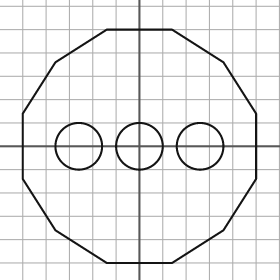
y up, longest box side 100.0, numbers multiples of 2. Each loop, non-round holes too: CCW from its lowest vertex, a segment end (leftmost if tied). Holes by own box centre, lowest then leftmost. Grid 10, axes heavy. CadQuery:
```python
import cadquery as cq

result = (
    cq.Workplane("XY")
    .moveTo(-14.0, -50.0)
    .lineTo(14.0, -50.0)
    .lineTo(36.0, -36.0)
    .lineTo(50.0, -14.0)
    .lineTo(50.0, 14.0)
    .lineTo(36.0, 36.0)
    .lineTo(14.0, 50.0)
    .lineTo(-14.0, 50.0)
    .lineTo(-36.0, 36.0)
    .lineTo(-50.0, 14.0)
    .lineTo(-50.0, -14.0)
    .lineTo(-36.0, -36.0)
    .close()
    .moveTo(-26.0, 0.0)
    .circle(10.0)
    .moveTo(0.0, 0.0)
    .circle(10.0)
    .moveTo(26.0, 0.0)
    .circle(10.0)
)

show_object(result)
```